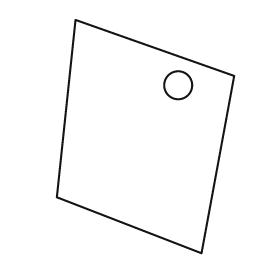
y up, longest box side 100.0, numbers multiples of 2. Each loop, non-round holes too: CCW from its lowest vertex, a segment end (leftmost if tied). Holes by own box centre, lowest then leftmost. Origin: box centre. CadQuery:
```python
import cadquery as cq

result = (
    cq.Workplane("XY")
    .moveTo(24.0, -50.0)
    .lineTo(38.0, 26.0)
    .lineTo(-30.0, 50.0)
    .lineTo(-38.0, -26.0)
    .close()
    .moveTo(14.0, 22.0)
    .circle(6.0)
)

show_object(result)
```